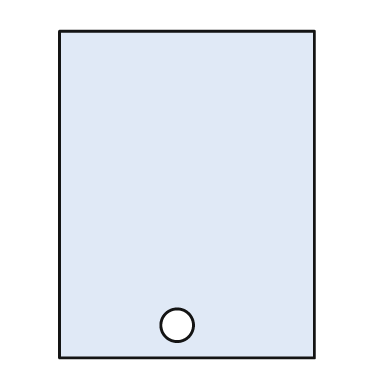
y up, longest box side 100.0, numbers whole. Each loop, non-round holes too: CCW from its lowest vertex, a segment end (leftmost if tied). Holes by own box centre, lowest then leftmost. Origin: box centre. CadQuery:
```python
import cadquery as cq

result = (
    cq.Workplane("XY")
    .moveTo(-39.0, -50.0)
    .lineTo(39.0, -50.0)
    .lineTo(39.0, 50.0)
    .lineTo(-39.0, 50.0)
    .close()
    .moveTo(-3.0, -40.0)
    .circle(5.0)
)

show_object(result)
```